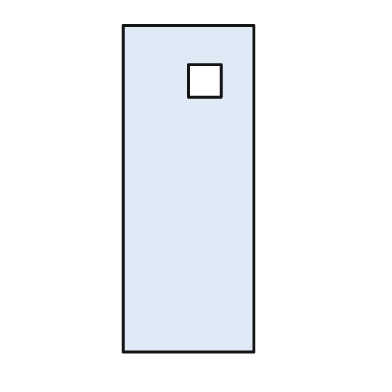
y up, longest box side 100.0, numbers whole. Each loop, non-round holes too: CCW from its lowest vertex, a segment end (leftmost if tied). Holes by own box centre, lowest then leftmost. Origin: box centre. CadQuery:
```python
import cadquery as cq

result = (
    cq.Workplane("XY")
    .moveTo(-20.0, -50.0)
    .lineTo(20.0, -50.0)
    .lineTo(20.0, 50.0)
    .lineTo(-20.0, 50.0)
    .close()
    .moveTo(0.0, 28.0)
    .lineTo(10.0, 28.0)
    .lineTo(10.0, 38.0)
    .lineTo(0.0, 38.0)
    .close()
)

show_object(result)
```